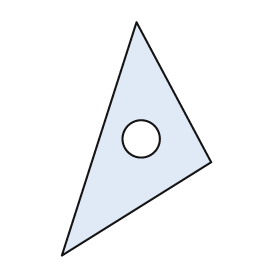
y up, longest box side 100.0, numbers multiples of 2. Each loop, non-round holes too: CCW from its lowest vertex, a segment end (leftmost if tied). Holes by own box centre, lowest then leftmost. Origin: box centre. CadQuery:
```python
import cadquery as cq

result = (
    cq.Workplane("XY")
    .moveTo(-32.0, -50.0)
    .lineTo(32.0, -10.0)
    .lineTo(0.0, 50.0)
    .close()
    .moveTo(2.0, 0.0)
    .circle(8.0)
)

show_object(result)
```